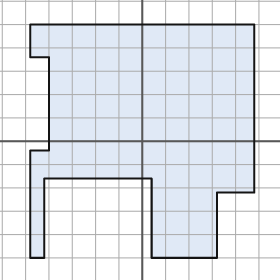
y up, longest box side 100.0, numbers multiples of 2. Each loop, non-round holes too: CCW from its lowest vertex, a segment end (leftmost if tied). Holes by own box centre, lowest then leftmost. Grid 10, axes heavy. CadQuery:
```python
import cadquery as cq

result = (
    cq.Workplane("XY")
    .moveTo(-48.0, -50.0)
    .lineTo(-42.0, -50.0)
    .lineTo(-42.0, -16.0)
    .lineTo(4.0, -16.0)
    .lineTo(4.0, -50.0)
    .lineTo(32.0, -50.0)
    .lineTo(32.0, -22.0)
    .lineTo(48.0, -22.0)
    .lineTo(48.0, 50.0)
    .lineTo(-48.0, 50.0)
    .lineTo(-48.0, 36.0)
    .lineTo(-40.0, 36.0)
    .lineTo(-40.0, -4.0)
    .lineTo(-48.0, -4.0)
    .close()
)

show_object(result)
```